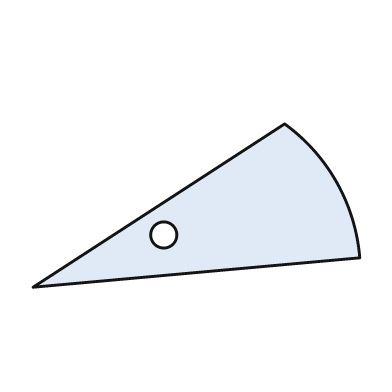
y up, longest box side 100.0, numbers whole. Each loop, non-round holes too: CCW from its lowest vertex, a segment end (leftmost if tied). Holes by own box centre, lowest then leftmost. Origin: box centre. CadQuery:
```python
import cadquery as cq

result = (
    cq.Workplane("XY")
    .moveTo(-50.0, -25.0)
    .lineTo(50.0, -16.0)
    .threePointArc((43.0, 7.0), (27.0, 25.0))
    .close()
    .moveTo(-10.0, -9.0)
    .circle(4.0)
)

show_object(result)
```